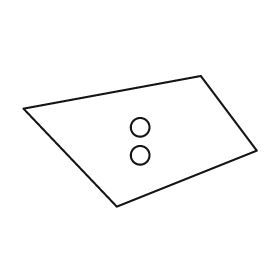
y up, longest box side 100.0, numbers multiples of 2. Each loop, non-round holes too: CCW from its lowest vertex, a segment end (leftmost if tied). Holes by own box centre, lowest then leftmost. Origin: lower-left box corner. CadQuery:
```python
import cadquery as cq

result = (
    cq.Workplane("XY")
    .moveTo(40.0, 0.0)
    .lineTo(100.0, 24.0)
    .lineTo(76.0, 56.0)
    .lineTo(0.0, 42.0)
    .close()
    .moveTo(50.0, 22.0)
    .circle(4.0)
    .moveTo(50.0, 34.0)
    .circle(4.0)
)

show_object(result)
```